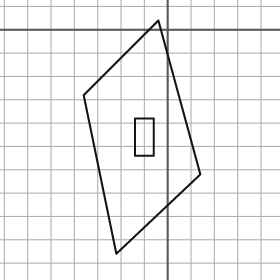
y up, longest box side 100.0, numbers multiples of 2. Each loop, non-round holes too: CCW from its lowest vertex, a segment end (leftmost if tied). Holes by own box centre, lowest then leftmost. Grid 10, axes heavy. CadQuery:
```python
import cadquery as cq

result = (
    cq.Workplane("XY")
    .moveTo(-22.0, -96.0)
    .lineTo(14.0, -62.0)
    .lineTo(-4.0, 4.0)
    .lineTo(-36.0, -28.0)
    .close()
    .moveTo(-14.0, -54.0)
    .lineTo(-6.0, -54.0)
    .lineTo(-6.0, -38.0)
    .lineTo(-14.0, -38.0)
    .close()
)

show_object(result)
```